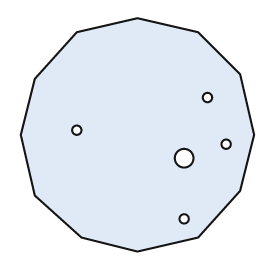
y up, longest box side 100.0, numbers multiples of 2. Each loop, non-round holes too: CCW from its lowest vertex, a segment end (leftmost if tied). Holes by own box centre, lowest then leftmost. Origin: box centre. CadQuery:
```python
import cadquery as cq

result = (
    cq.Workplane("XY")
    .moveTo(0.0, -50.0)
    .lineTo(26.0, -44.0)
    .lineTo(44.0, -24.0)
    .lineTo(50.0, 0.0)
    .lineTo(44.0, 26.0)
    .lineTo(26.0, 44.0)
    .lineTo(0.0, 50.0)
    .lineTo(-26.0, 44.0)
    .lineTo(-44.0, 24.0)
    .lineTo(-50.0, 0.0)
    .lineTo(-44.0, -26.0)
    .lineTo(-24.0, -44.0)
    .close()
    .moveTo(20.0, -36.0)
    .circle(2.0)
    .moveTo(20.0, -10.0)
    .circle(4.0)
    .moveTo(38.0, -4.0)
    .circle(2.0)
    .moveTo(-26.0, 2.0)
    .circle(2.0)
    .moveTo(30.0, 16.0)
    .circle(2.0)
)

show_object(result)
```